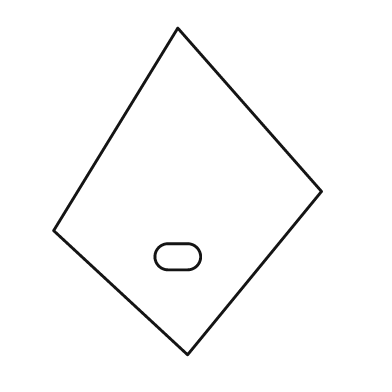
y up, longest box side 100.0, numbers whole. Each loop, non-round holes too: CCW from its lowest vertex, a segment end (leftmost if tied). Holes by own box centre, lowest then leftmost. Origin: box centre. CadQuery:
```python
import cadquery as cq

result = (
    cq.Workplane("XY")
    .moveTo(0.0, -50.0)
    .lineTo(41.0, 0.0)
    .lineTo(-3.0, 50.0)
    .lineTo(-41.0, -12.0)
    .close()
    .moveTo(-6.0, -24.0)
    .lineTo(0.0, -24.0)
    .threePointArc((4.0, -20.0), (0.0, -16.0))
    .lineTo(-6.0, -16.0)
    .threePointArc((-10.0, -20.0), (-6.0, -24.0))
    .close()
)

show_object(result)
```